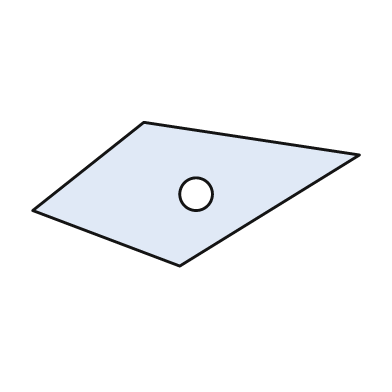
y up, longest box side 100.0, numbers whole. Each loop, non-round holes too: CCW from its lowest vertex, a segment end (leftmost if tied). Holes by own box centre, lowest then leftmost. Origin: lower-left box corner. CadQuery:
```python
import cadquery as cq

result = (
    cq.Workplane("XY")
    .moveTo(45.0, 0.0)
    .lineTo(100.0, 34.0)
    .lineTo(34.0, 44.0)
    .lineTo(0.0, 17.0)
    .close()
    .moveTo(50.0, 22.0)
    .circle(5.0)
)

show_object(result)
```